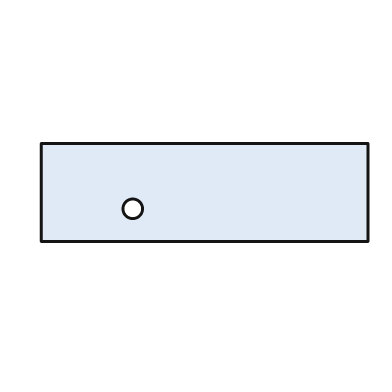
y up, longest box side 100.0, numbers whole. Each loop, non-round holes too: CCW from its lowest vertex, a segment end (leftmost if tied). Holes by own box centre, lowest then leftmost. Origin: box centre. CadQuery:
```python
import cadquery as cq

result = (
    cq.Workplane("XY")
    .moveTo(-50.0, -15.0)
    .lineTo(50.0, -15.0)
    .lineTo(50.0, 15.0)
    .lineTo(-50.0, 15.0)
    .close()
    .moveTo(-22.0, -5.0)
    .circle(3.0)
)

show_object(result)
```